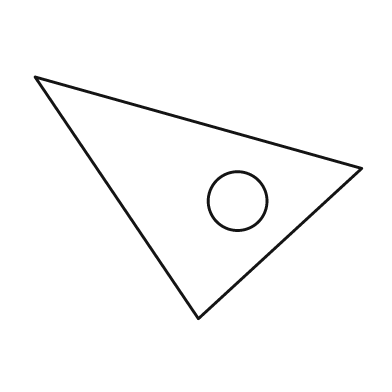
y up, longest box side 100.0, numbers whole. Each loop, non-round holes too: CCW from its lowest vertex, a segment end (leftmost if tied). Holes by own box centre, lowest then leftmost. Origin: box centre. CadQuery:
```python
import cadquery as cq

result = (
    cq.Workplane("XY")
    .moveTo(0.0, -37.0)
    .lineTo(50.0, 9.0)
    .lineTo(-50.0, 37.0)
    .close()
    .moveTo(12.0, -1.0)
    .circle(9.0)
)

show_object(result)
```